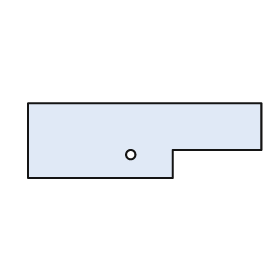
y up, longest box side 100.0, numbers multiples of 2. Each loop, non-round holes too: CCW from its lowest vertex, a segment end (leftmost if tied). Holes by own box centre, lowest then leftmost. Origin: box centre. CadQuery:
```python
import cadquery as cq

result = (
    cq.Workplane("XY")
    .moveTo(-50.0, -16.0)
    .lineTo(12.0, -16.0)
    .lineTo(12.0, -4.0)
    .lineTo(50.0, -4.0)
    .lineTo(50.0, 16.0)
    .lineTo(-50.0, 16.0)
    .close()
    .moveTo(-6.0, -6.0)
    .circle(2.0)
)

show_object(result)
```